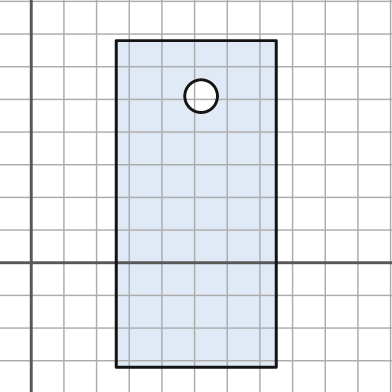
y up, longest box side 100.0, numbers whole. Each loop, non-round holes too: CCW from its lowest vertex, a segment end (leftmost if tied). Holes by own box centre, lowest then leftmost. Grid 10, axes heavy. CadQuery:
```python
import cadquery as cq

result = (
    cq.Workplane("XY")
    .moveTo(26.0, -32.0)
    .lineTo(75.0, -32.0)
    .lineTo(75.0, 68.0)
    .lineTo(26.0, 68.0)
    .close()
    .moveTo(52.0, 51.0)
    .circle(5.0)
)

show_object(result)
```